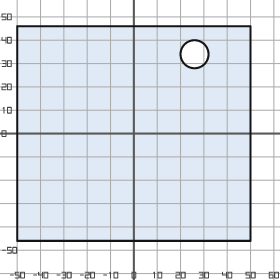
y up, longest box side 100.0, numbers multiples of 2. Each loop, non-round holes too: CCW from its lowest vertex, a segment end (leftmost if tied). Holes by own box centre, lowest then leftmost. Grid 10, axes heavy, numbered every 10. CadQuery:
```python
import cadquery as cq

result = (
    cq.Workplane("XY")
    .moveTo(-50.0, -46.0)
    .lineTo(50.0, -46.0)
    .lineTo(50.0, 46.0)
    .lineTo(-50.0, 46.0)
    .close()
    .moveTo(26.0, 34.0)
    .circle(6.0)
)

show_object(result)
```